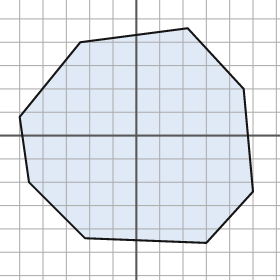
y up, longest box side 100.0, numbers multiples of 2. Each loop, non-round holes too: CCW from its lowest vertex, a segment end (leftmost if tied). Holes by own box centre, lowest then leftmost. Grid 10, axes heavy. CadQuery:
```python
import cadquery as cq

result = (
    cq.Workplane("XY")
    .moveTo(30.0, -46.0)
    .lineTo(50.0, -24.0)
    .lineTo(46.0, 20.0)
    .lineTo(22.0, 46.0)
    .lineTo(-24.0, 40.0)
    .lineTo(-50.0, 8.0)
    .lineTo(-46.0, -20.0)
    .lineTo(-22.0, -44.0)
    .close()
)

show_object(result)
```